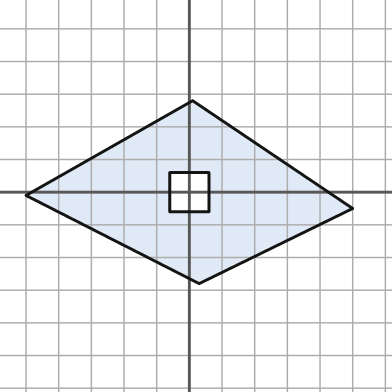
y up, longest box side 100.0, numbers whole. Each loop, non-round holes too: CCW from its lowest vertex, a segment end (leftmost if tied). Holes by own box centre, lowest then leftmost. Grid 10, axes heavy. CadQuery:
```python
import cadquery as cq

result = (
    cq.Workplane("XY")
    .moveTo(3.0, -28.0)
    .lineTo(50.0, -5.0)
    .lineTo(1.0, 28.0)
    .lineTo(-50.0, -1.0)
    .close()
    .moveTo(-6.0, -6.0)
    .lineTo(6.0, -6.0)
    .lineTo(6.0, 6.0)
    .lineTo(-6.0, 6.0)
    .close()
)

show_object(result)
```